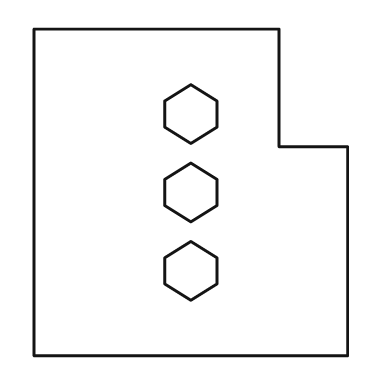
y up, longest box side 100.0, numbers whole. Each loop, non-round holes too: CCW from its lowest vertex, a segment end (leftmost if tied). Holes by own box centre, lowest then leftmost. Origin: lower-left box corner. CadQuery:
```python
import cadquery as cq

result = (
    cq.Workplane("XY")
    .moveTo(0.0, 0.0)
    .lineTo(96.0, 0.0)
    .lineTo(96.0, 64.0)
    .lineTo(75.0, 64.0)
    .lineTo(75.0, 100.0)
    .lineTo(0.0, 100.0)
    .close()
    .moveTo(48.0, 17.0)
    .lineTo(56.0, 22.0)
    .lineTo(56.0, 30.0)
    .lineTo(48.0, 35.0)
    .lineTo(40.0, 30.0)
    .lineTo(40.0, 22.0)
    .close()
    .moveTo(48.0, 41.0)
    .lineTo(56.0, 46.0)
    .lineTo(56.0, 54.0)
    .lineTo(48.0, 59.0)
    .lineTo(40.0, 54.0)
    .lineTo(40.0, 46.0)
    .close()
    .moveTo(48.0, 65.0)
    .lineTo(56.0, 70.0)
    .lineTo(56.0, 78.0)
    .lineTo(48.0, 83.0)
    .lineTo(40.0, 78.0)
    .lineTo(40.0, 70.0)
    .close()
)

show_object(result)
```